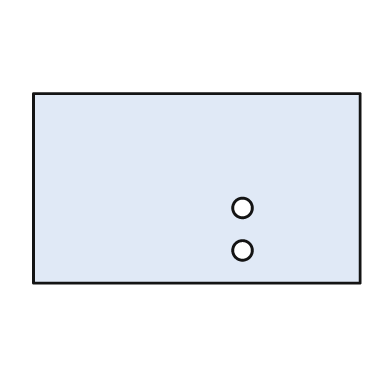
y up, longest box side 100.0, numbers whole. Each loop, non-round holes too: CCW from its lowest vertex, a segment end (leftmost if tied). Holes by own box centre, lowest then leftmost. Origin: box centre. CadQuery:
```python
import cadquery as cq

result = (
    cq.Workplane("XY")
    .moveTo(-50.0, -29.0)
    .lineTo(50.0, -29.0)
    .lineTo(50.0, 29.0)
    .lineTo(-50.0, 29.0)
    .close()
    .moveTo(14.0, -19.0)
    .circle(3.0)
    .moveTo(14.0, -6.0)
    .circle(3.0)
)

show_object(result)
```